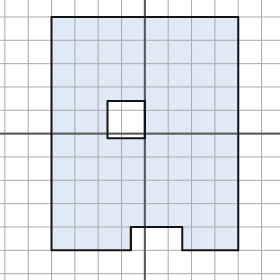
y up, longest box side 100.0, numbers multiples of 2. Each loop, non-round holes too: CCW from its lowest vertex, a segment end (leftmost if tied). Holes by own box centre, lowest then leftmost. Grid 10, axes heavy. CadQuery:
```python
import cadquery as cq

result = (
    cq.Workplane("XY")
    .moveTo(-40.0, -50.0)
    .lineTo(-6.0, -50.0)
    .lineTo(-6.0, -40.0)
    .lineTo(16.0, -40.0)
    .lineTo(16.0, -50.0)
    .lineTo(40.0, -50.0)
    .lineTo(40.0, 50.0)
    .lineTo(-40.0, 50.0)
    .close()
    .moveTo(-16.0, -2.0)
    .lineTo(0.0, -2.0)
    .lineTo(0.0, 14.0)
    .lineTo(-16.0, 14.0)
    .close()
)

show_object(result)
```